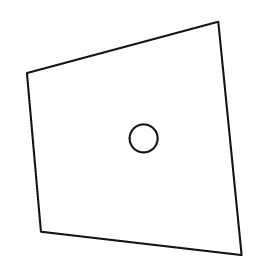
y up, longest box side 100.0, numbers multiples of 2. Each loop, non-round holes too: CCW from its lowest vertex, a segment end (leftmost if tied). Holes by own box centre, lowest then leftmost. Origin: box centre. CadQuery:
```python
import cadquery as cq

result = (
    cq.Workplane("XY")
    .moveTo(46.0, -50.0)
    .lineTo(36.0, 50.0)
    .lineTo(-46.0, 28.0)
    .lineTo(-40.0, -40.0)
    .close()
    .moveTo(4.0, 0.0)
    .circle(6.0)
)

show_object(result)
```